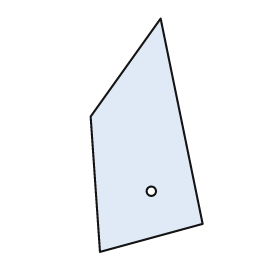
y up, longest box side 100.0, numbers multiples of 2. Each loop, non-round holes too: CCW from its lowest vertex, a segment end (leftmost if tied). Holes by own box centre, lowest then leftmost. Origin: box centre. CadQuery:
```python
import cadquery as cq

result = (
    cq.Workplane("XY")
    .moveTo(-20.0, -50.0)
    .lineTo(24.0, -38.0)
    .lineTo(6.0, 50.0)
    .lineTo(-24.0, 8.0)
    .close()
    .moveTo(2.0, -24.0)
    .circle(2.0)
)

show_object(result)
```